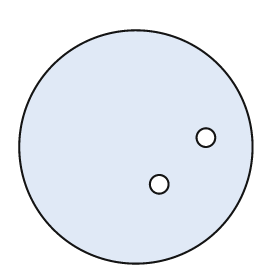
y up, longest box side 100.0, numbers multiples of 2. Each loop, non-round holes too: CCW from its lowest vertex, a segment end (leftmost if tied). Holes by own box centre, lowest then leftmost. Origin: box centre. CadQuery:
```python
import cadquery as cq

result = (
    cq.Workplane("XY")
    .moveTo(0.0, 0.0)
    .circle(50.0)
    .moveTo(10.0, -16.0)
    .circle(4.0)
    .moveTo(30.0, 4.0)
    .circle(4.0)
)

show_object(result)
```